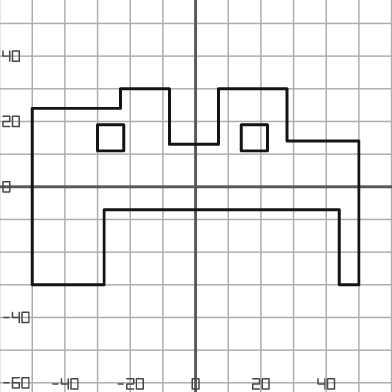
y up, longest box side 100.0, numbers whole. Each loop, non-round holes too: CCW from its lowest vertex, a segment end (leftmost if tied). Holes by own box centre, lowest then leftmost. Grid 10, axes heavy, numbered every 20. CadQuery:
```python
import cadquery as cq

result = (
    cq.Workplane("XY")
    .moveTo(-50.0, -30.0)
    .lineTo(-28.0, -30.0)
    .lineTo(-28.0, -7.0)
    .lineTo(44.0, -7.0)
    .lineTo(44.0, -30.0)
    .lineTo(50.0, -30.0)
    .lineTo(50.0, 14.0)
    .lineTo(28.0, 14.0)
    .lineTo(28.0, 30.0)
    .lineTo(7.0, 30.0)
    .lineTo(7.0, 13.0)
    .lineTo(-8.0, 13.0)
    .lineTo(-8.0, 30.0)
    .lineTo(-23.0, 30.0)
    .lineTo(-23.0, 24.0)
    .lineTo(-50.0, 24.0)
    .close()
    .moveTo(-30.0, 11.0)
    .lineTo(-22.0, 11.0)
    .lineTo(-22.0, 19.0)
    .lineTo(-30.0, 19.0)
    .close()
    .moveTo(14.0, 11.0)
    .lineTo(22.0, 11.0)
    .lineTo(22.0, 19.0)
    .lineTo(14.0, 19.0)
    .close()
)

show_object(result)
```